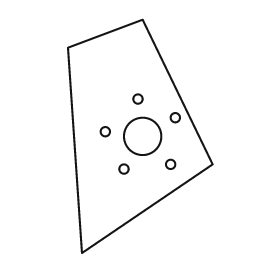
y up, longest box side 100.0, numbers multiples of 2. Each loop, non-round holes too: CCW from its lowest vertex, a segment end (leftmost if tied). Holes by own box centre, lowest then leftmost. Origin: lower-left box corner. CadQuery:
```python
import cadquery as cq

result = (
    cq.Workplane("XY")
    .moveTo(6.0, 0.0)
    .lineTo(62.0, 38.0)
    .lineTo(32.0, 100.0)
    .lineTo(0.0, 88.0)
    .close()
    .moveTo(24.0, 36.0)
    .circle(2.0)
    .moveTo(44.0, 38.0)
    .circle(2.0)
    .moveTo(32.0, 50.0)
    .circle(8.0)
    .moveTo(16.0, 52.0)
    .circle(2.0)
    .moveTo(46.0, 58.0)
    .circle(2.0)
    .moveTo(30.0, 66.0)
    .circle(2.0)
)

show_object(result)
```